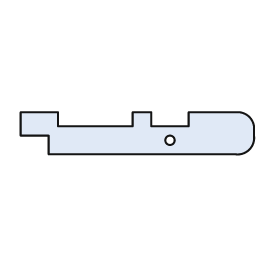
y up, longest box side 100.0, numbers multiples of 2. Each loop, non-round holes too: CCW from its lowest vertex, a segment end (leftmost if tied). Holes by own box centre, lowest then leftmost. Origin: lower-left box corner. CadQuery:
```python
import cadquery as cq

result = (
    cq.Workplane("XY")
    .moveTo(12.0, 0.0)
    .lineTo(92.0, 0.0)
    .threePointArc((98.0, 2.0), (100.0, 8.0))
    .lineTo(100.0, 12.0)
    .threePointArc((98.0, 16.0), (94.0, 18.0))
    .lineTo(72.0, 18.0)
    .lineTo(72.0, 12.0)
    .lineTo(56.0, 12.0)
    .lineTo(56.0, 18.0)
    .lineTo(48.0, 18.0)
    .lineTo(48.0, 12.0)
    .lineTo(16.0, 12.0)
    .lineTo(16.0, 18.0)
    .lineTo(0.0, 18.0)
    .lineTo(0.0, 8.0)
    .lineTo(12.0, 8.0)
    .close()
    .moveTo(64.0, 6.0)
    .circle(2.0)
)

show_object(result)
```